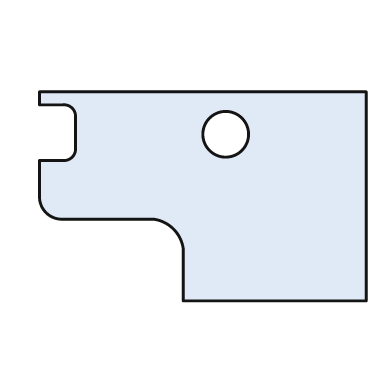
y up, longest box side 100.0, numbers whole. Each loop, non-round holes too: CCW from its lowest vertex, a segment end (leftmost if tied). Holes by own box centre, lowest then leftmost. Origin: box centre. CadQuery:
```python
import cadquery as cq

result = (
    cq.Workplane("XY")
    .moveTo(-6.0, -32.0)
    .lineTo(50.0, -32.0)
    .lineTo(50.0, 32.0)
    .lineTo(-50.0, 32.0)
    .lineTo(-50.0, 28.0)
    .lineTo(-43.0, 28.0)
    .threePointArc((-40.0, 27.0), (-39.0, 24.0))
    .lineTo(-39.0, 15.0)
    .threePointArc((-40.0, 12.0), (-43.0, 11.0))
    .lineTo(-50.0, 11.0)
    .lineTo(-50.0, 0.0)
    .threePointArc((-48.0, -5.0), (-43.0, -7.0))
    .lineTo(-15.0, -7.0)
    .threePointArc((-9.0, -10.0), (-6.0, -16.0))
    .close()
    .moveTo(7.0, 19.0)
    .circle(7.0)
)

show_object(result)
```